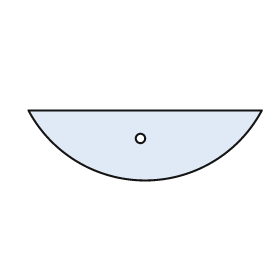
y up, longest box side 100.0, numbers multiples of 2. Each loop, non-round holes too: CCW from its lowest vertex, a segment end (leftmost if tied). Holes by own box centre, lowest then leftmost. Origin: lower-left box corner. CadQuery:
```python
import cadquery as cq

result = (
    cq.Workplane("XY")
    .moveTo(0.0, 30.0)
    .threePointArc((50.0, 0.0), (100.0, 30.0))
    .close()
    .moveTo(48.0, 18.0)
    .circle(2.0)
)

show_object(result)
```